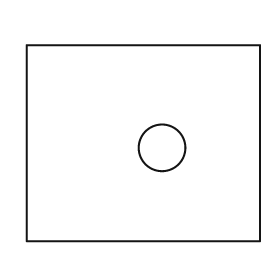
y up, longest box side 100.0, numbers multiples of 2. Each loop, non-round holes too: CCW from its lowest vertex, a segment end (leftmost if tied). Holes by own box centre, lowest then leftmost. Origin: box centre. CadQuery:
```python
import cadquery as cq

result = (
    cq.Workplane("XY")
    .moveTo(-50.0, -42.0)
    .lineTo(50.0, -42.0)
    .lineTo(50.0, 42.0)
    .lineTo(-50.0, 42.0)
    .close()
    .moveTo(8.0, -2.0)
    .circle(10.0)
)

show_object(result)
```